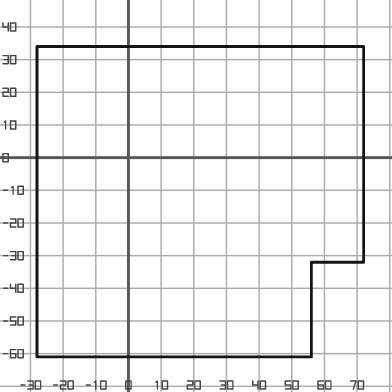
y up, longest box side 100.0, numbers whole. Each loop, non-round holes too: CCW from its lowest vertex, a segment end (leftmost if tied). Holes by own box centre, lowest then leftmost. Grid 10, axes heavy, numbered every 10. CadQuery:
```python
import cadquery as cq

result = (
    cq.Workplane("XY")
    .moveTo(-28.0, -61.0)
    .lineTo(56.0, -61.0)
    .lineTo(56.0, -32.0)
    .lineTo(72.0, -32.0)
    .lineTo(72.0, 34.0)
    .lineTo(-28.0, 34.0)
    .close()
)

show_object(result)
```